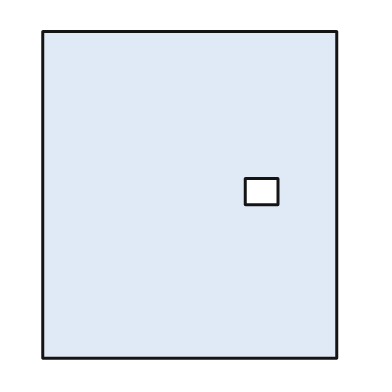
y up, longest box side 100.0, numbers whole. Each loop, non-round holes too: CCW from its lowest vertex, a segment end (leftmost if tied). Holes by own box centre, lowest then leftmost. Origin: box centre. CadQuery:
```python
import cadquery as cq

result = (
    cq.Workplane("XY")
    .moveTo(-45.0, -50.0)
    .lineTo(45.0, -50.0)
    .lineTo(45.0, 50.0)
    .lineTo(-45.0, 50.0)
    .close()
    .moveTo(17.0, -3.0)
    .lineTo(27.0, -3.0)
    .lineTo(27.0, 5.0)
    .lineTo(17.0, 5.0)
    .close()
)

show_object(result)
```